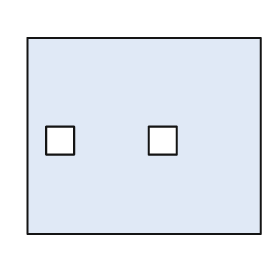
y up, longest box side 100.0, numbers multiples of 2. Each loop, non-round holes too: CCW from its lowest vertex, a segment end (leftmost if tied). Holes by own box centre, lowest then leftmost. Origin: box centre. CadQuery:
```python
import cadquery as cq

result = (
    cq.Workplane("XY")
    .moveTo(-50.0, -42.0)
    .lineTo(50.0, -42.0)
    .lineTo(50.0, 42.0)
    .lineTo(-50.0, 42.0)
    .close()
    .moveTo(-42.0, -8.0)
    .lineTo(-30.0, -8.0)
    .lineTo(-30.0, 4.0)
    .lineTo(-42.0, 4.0)
    .close()
    .moveTo(2.0, -8.0)
    .lineTo(14.0, -8.0)
    .lineTo(14.0, 4.0)
    .lineTo(2.0, 4.0)
    .close()
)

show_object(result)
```